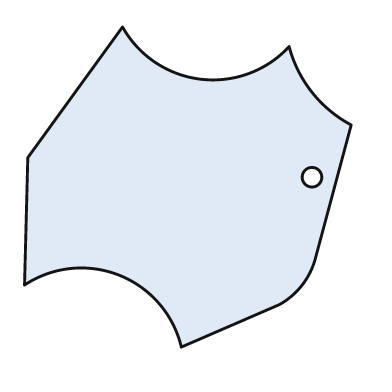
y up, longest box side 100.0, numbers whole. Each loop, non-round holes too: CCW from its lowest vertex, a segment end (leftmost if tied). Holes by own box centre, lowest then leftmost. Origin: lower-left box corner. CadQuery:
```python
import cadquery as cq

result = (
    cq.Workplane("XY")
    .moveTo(48.0, 0.0)
    .lineTo(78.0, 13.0)
    .threePointArc((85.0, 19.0), (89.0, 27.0))
    .lineTo(100.0, 68.0)
    .threePointArc((88.0, 78.0), (81.0, 92.0))
    .threePointArc((54.0, 82.0), (30.0, 98.0))
    .lineTo(1.0, 58.0)
    .lineTo(0.0, 19.0)
    .threePointArc((29.0, 22.0), (48.0, 0.0))
    .close()
    .moveTo(88.0, 52.0)
    .circle(3.0)
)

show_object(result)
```